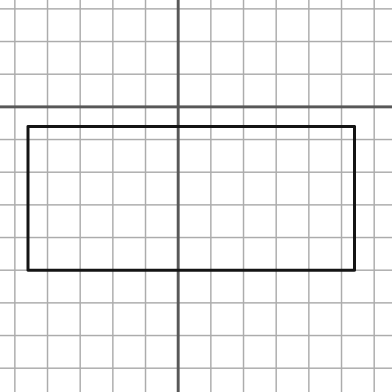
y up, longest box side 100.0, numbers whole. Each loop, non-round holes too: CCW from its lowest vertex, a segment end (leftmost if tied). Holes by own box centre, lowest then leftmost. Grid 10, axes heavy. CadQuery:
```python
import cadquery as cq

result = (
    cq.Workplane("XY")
    .moveTo(-46.0, -50.0)
    .lineTo(54.0, -50.0)
    .lineTo(54.0, -6.0)
    .lineTo(-46.0, -6.0)
    .close()
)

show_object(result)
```